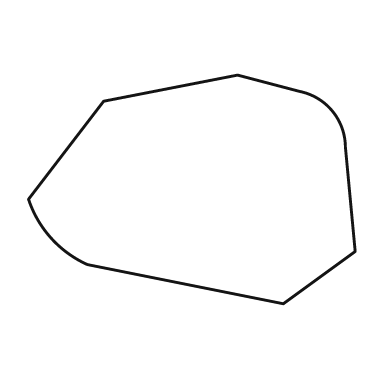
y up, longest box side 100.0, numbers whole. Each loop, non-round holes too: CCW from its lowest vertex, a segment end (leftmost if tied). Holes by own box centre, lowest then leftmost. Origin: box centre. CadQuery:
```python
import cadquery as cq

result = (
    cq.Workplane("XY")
    .moveTo(28.0, -35.0)
    .lineTo(50.0, -19.0)
    .lineTo(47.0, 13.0)
    .threePointArc((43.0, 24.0), (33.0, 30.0))
    .lineTo(14.0, 35.0)
    .lineTo(-27.0, 27.0)
    .lineTo(-50.0, -3.0)
    .threePointArc((-43.0, -15.0), (-32.0, -23.0))
    .close()
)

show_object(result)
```